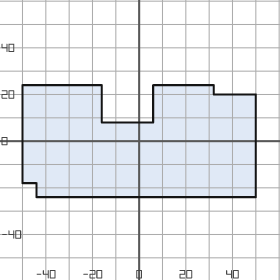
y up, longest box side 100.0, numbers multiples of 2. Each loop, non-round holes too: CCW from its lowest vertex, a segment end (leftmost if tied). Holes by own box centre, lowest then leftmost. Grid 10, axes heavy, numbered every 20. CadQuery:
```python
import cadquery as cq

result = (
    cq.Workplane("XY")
    .moveTo(-44.0, -24.0)
    .lineTo(50.0, -24.0)
    .lineTo(50.0, 20.0)
    .lineTo(32.0, 20.0)
    .lineTo(32.0, 24.0)
    .lineTo(6.0, 24.0)
    .lineTo(6.0, 8.0)
    .lineTo(-16.0, 8.0)
    .lineTo(-16.0, 24.0)
    .lineTo(-50.0, 24.0)
    .lineTo(-50.0, -18.0)
    .lineTo(-44.0, -18.0)
    .close()
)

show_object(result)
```